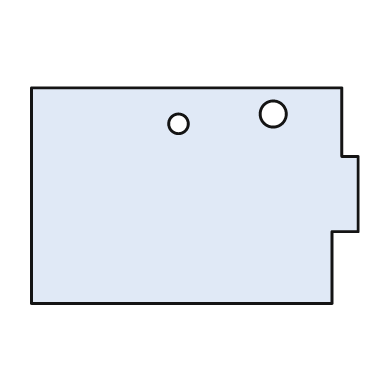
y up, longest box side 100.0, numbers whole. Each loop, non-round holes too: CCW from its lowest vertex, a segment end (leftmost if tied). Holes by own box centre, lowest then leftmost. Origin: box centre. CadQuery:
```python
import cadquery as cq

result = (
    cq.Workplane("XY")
    .moveTo(-50.0, -33.0)
    .lineTo(42.0, -33.0)
    .lineTo(42.0, -11.0)
    .lineTo(50.0, -11.0)
    .lineTo(50.0, 12.0)
    .lineTo(45.0, 12.0)
    .lineTo(45.0, 33.0)
    .lineTo(-50.0, 33.0)
    .close()
    .moveTo(-5.0, 22.0)
    .circle(3.0)
    .moveTo(24.0, 25.0)
    .circle(4.0)
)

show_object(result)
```